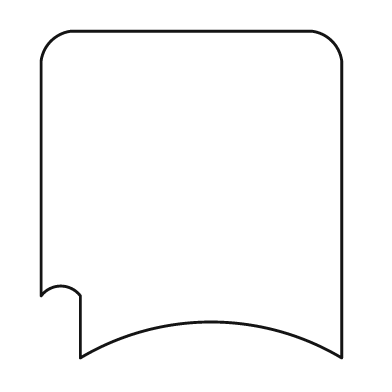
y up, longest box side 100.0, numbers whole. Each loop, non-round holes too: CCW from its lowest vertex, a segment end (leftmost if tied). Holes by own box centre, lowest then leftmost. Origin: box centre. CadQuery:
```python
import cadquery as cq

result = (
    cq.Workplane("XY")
    .moveTo(-34.0, -50.0)
    .threePointArc((6.0, -39.0), (46.0, -50.0))
    .lineTo(46.0, 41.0)
    .threePointArc((43.0, 47.0), (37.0, 50.0))
    .lineTo(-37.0, 50.0)
    .threePointArc((-43.0, 47.0), (-46.0, 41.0))
    .lineTo(-46.0, -31.0)
    .threePointArc((-40.0, -28.0), (-34.0, -31.0))
    .close()
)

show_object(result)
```